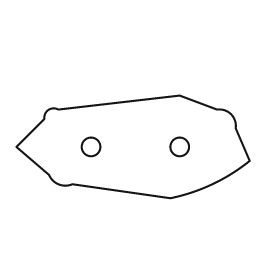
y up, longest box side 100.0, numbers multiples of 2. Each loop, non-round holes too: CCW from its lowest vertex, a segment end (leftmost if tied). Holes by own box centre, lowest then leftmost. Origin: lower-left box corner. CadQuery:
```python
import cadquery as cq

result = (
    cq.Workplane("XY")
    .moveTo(66.0, 0.0)
    .threePointArc((84.0, 6.0), (100.0, 16.0))
    .lineTo(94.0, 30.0)
    .threePointArc((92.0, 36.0), (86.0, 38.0))
    .lineTo(70.0, 44.0)
    .lineTo(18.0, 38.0)
    .threePointArc((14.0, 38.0), (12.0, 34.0))
    .lineTo(0.0, 22.0)
    .lineTo(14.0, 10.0)
    .threePointArc((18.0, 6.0), (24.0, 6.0))
    .close()
    .moveTo(32.0, 22.0)
    .circle(4.0)
    .moveTo(70.0, 22.0)
    .circle(4.0)
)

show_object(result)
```